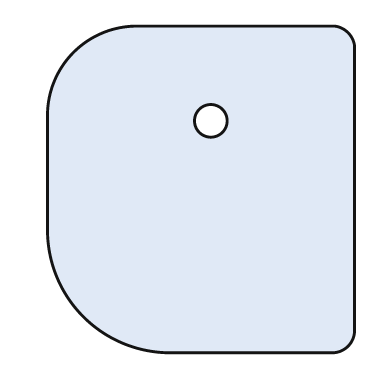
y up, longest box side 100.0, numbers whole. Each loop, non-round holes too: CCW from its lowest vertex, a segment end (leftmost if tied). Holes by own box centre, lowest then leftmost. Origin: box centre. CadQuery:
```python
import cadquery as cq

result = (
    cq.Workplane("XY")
    .moveTo(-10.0, -50.0)
    .lineTo(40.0, -50.0)
    .threePointArc((45.0, -48.0), (47.0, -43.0))
    .lineTo(47.0, 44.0)
    .threePointArc((45.0, 48.0), (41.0, 50.0))
    .lineTo(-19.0, 50.0)
    .threePointArc((-39.0, 42.0), (-47.0, 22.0))
    .lineTo(-47.0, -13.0)
    .threePointArc((-36.0, -39.0), (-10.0, -50.0))
    .close()
    .moveTo(3.0, 21.0)
    .circle(5.0)
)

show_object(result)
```